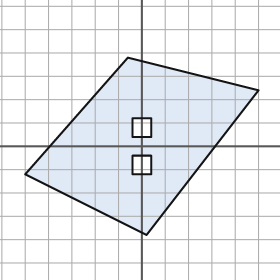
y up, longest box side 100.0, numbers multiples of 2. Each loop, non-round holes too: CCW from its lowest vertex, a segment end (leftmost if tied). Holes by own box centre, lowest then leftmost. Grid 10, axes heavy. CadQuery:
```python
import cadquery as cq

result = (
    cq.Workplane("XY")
    .moveTo(2.0, -38.0)
    .lineTo(50.0, 24.0)
    .lineTo(-6.0, 38.0)
    .lineTo(-50.0, -12.0)
    .close()
    .moveTo(-4.0, -12.0)
    .lineTo(4.0, -12.0)
    .lineTo(4.0, -4.0)
    .lineTo(-4.0, -4.0)
    .close()
    .moveTo(-4.0, 4.0)
    .lineTo(4.0, 4.0)
    .lineTo(4.0, 12.0)
    .lineTo(-4.0, 12.0)
    .close()
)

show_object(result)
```